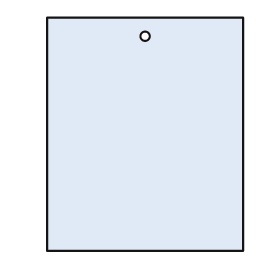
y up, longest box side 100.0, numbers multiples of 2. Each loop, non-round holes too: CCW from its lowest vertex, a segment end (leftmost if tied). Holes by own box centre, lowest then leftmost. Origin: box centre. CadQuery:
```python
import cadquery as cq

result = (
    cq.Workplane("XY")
    .moveTo(-42.0, -50.0)
    .lineTo(42.0, -50.0)
    .lineTo(42.0, 50.0)
    .lineTo(-42.0, 50.0)
    .close()
    .moveTo(0.0, 42.0)
    .circle(2.0)
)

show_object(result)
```